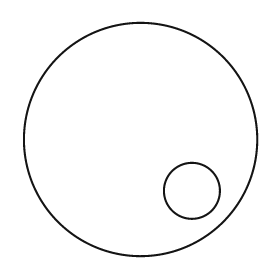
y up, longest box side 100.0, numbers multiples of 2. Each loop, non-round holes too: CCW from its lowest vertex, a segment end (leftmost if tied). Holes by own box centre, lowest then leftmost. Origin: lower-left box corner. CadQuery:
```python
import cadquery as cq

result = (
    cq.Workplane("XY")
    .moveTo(50.0, 50.0)
    .circle(50.0)
    .moveTo(72.0, 28.0)
    .circle(12.0)
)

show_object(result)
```